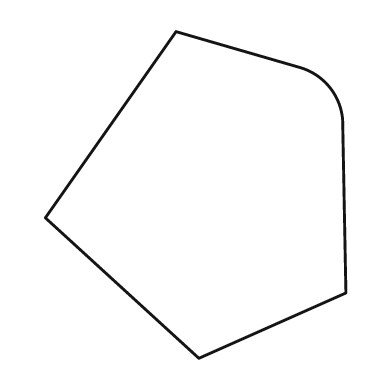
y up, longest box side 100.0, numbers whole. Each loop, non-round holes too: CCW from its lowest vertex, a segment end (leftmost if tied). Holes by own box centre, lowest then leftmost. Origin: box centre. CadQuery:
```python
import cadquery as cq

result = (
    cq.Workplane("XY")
    .moveTo(1.0, -50.0)
    .lineTo(46.0, -30.0)
    .lineTo(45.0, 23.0)
    .threePointArc((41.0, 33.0), (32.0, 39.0))
    .lineTo(-6.0, 50.0)
    .lineTo(-46.0, -7.0)
    .close()
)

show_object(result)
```